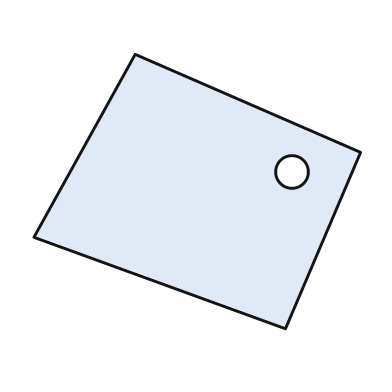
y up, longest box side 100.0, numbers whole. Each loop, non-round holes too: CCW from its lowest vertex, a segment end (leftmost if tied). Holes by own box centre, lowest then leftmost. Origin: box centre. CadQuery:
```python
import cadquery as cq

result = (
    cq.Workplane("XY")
    .moveTo(27.0, -42.0)
    .lineTo(50.0, 12.0)
    .lineTo(-19.0, 42.0)
    .lineTo(-50.0, -14.0)
    .close()
    .moveTo(29.0, 6.0)
    .circle(5.0)
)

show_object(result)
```